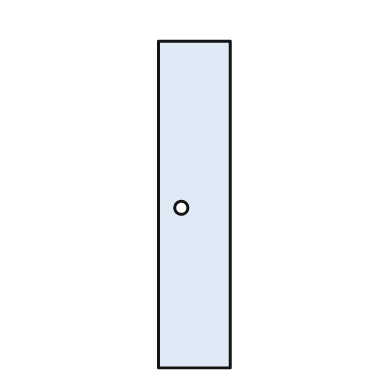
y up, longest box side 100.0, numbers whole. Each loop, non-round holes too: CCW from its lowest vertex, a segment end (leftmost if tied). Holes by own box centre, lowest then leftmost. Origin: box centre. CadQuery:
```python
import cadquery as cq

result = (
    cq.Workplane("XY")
    .moveTo(-11.0, -50.0)
    .lineTo(11.0, -50.0)
    .lineTo(11.0, 50.0)
    .lineTo(-11.0, 50.0)
    .close()
    .moveTo(-4.0, -1.0)
    .circle(2.0)
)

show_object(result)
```